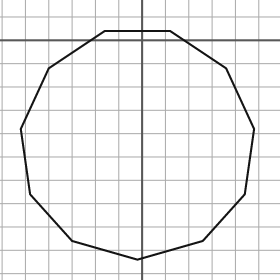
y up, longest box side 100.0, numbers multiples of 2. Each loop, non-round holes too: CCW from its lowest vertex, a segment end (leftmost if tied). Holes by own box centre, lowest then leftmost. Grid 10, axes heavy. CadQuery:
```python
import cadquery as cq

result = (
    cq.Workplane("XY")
    .moveTo(-2.0, -94.0)
    .lineTo(26.0, -86.0)
    .lineTo(44.0, -66.0)
    .lineTo(48.0, -38.0)
    .lineTo(36.0, -12.0)
    .lineTo(12.0, 4.0)
    .lineTo(-16.0, 4.0)
    .lineTo(-40.0, -12.0)
    .lineTo(-52.0, -38.0)
    .lineTo(-48.0, -66.0)
    .lineTo(-30.0, -86.0)
    .close()
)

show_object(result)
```